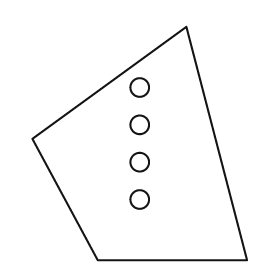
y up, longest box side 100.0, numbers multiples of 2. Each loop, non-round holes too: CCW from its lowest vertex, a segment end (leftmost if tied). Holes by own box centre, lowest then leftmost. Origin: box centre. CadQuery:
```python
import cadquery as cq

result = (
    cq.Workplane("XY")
    .moveTo(-18.0, -50.0)
    .lineTo(46.0, -50.0)
    .lineTo(20.0, 50.0)
    .lineTo(-46.0, 2.0)
    .close()
    .moveTo(0.0, -24.0)
    .circle(4.0)
    .moveTo(0.0, -8.0)
    .circle(4.0)
    .moveTo(0.0, 8.0)
    .circle(4.0)
    .moveTo(0.0, 24.0)
    .circle(4.0)
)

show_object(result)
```